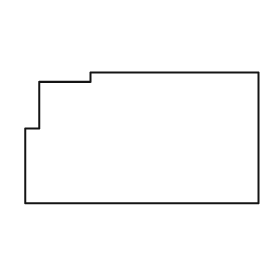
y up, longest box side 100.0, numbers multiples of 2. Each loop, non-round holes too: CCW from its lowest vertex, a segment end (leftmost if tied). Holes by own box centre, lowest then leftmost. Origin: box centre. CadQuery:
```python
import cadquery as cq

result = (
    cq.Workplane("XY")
    .moveTo(-50.0, -28.0)
    .lineTo(50.0, -28.0)
    .lineTo(50.0, 28.0)
    .lineTo(-22.0, 28.0)
    .lineTo(-22.0, 24.0)
    .lineTo(-44.0, 24.0)
    .lineTo(-44.0, 4.0)
    .lineTo(-50.0, 4.0)
    .close()
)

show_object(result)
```